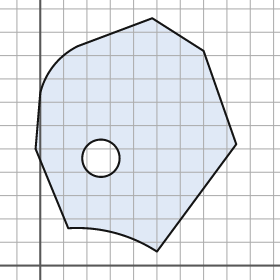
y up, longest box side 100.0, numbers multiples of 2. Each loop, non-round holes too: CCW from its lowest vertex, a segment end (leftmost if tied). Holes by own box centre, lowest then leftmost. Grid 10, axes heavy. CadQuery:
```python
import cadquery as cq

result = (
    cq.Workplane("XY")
    .moveTo(50.0, 6.0)
    .lineTo(84.0, 52.0)
    .lineTo(70.0, 92.0)
    .lineTo(48.0, 106.0)
    .lineTo(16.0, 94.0)
    .threePointArc((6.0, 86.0), (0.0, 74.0))
    .lineTo(-2.0, 50.0)
    .lineTo(12.0, 16.0)
    .threePointArc((32.0, 14.0), (50.0, 6.0))
    .close()
    .moveTo(26.0, 46.0)
    .circle(8.0)
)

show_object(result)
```